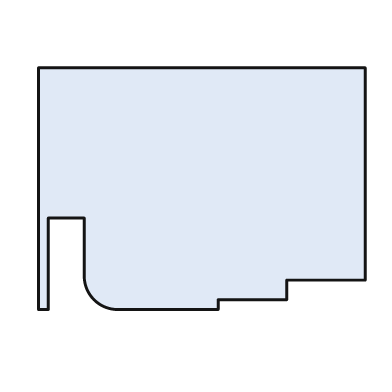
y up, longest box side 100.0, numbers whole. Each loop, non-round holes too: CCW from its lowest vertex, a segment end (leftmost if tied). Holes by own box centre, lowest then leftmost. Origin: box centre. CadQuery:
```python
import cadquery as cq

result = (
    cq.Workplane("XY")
    .moveTo(-50.0, -37.0)
    .lineTo(-47.0, -37.0)
    .lineTo(-47.0, -9.0)
    .lineTo(-36.0, -9.0)
    .lineTo(-36.0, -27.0)
    .threePointArc((-33.0, -34.0), (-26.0, -37.0))
    .lineTo(5.0, -37.0)
    .lineTo(5.0, -34.0)
    .lineTo(26.0, -34.0)
    .lineTo(26.0, -28.0)
    .lineTo(50.0, -28.0)
    .lineTo(50.0, 37.0)
    .lineTo(-50.0, 37.0)
    .close()
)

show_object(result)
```